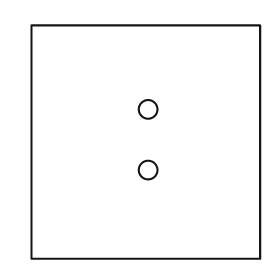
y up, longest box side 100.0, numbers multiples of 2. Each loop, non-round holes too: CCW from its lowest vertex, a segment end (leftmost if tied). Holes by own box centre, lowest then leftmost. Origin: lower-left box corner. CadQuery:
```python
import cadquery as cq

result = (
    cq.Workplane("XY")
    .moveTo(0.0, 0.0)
    .lineTo(98.0, 0.0)
    .lineTo(98.0, 100.0)
    .lineTo(0.0, 100.0)
    .close()
    .moveTo(50.0, 38.0)
    .circle(4.0)
    .moveTo(50.0, 64.0)
    .circle(4.0)
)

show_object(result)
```